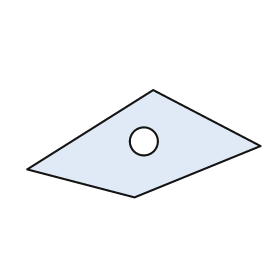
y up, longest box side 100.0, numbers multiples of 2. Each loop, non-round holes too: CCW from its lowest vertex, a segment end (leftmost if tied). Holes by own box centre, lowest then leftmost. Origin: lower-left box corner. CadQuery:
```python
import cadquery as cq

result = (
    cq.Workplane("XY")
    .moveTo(46.0, 0.0)
    .lineTo(100.0, 22.0)
    .lineTo(54.0, 46.0)
    .lineTo(0.0, 12.0)
    .close()
    .moveTo(50.0, 24.0)
    .circle(6.0)
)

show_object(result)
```